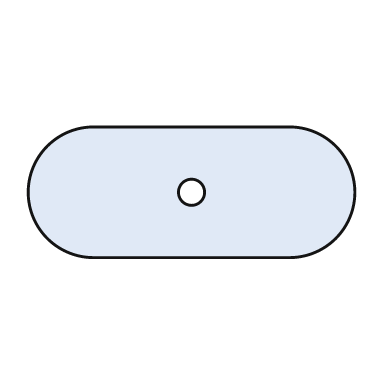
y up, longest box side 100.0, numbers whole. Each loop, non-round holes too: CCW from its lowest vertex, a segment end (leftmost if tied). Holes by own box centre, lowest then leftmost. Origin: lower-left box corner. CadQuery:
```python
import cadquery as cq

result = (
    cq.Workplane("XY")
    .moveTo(20.0, 0.0)
    .lineTo(80.0, 0.0)
    .threePointArc((100.0, 20.0), (80.0, 40.0))
    .lineTo(20.0, 40.0)
    .threePointArc((0.0, 20.0), (20.0, 0.0))
    .close()
    .moveTo(50.0, 20.0)
    .circle(4.0)
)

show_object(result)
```